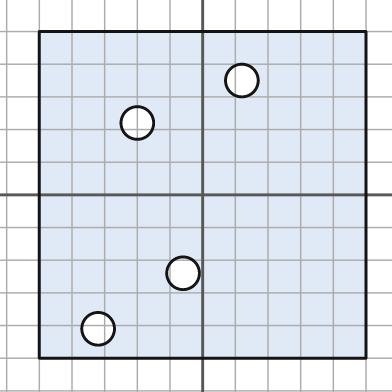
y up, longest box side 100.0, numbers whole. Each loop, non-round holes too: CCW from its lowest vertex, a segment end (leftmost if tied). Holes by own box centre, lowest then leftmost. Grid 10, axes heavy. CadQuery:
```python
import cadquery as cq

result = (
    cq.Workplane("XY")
    .moveTo(-50.0, -50.0)
    .lineTo(50.0, -50.0)
    .lineTo(50.0, 50.0)
    .lineTo(-50.0, 50.0)
    .close()
    .moveTo(-32.0, -41.0)
    .circle(5.0)
    .moveTo(-6.0, -24.0)
    .circle(5.0)
    .moveTo(-20.0, 22.0)
    .circle(5.0)
    .moveTo(12.0, 35.0)
    .circle(5.0)
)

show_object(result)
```